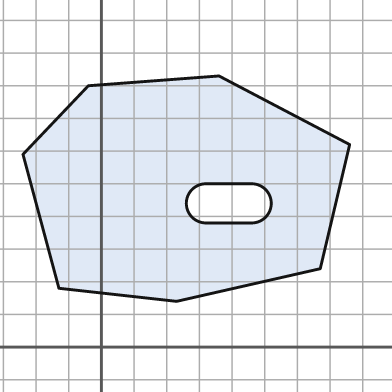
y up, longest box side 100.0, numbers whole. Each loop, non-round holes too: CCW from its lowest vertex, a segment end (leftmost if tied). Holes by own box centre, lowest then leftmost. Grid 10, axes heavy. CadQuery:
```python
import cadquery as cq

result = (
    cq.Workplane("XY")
    .moveTo(23.0, 14.0)
    .lineTo(67.0, 24.0)
    .lineTo(76.0, 62.0)
    .lineTo(36.0, 83.0)
    .lineTo(-4.0, 80.0)
    .lineTo(-24.0, 59.0)
    .lineTo(-13.0, 18.0)
    .close()
    .moveTo(32.0, 38.0)
    .lineTo(46.0, 38.0)
    .threePointArc((52.0, 44.0), (46.0, 50.0))
    .lineTo(32.0, 50.0)
    .threePointArc((26.0, 44.0), (32.0, 38.0))
    .close()
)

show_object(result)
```